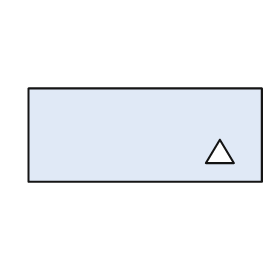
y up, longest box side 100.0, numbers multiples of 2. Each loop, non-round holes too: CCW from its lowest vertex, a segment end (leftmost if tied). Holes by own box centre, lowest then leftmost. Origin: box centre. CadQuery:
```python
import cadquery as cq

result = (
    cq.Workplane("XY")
    .moveTo(-50.0, -20.0)
    .lineTo(50.0, -20.0)
    .lineTo(50.0, 20.0)
    .lineTo(-50.0, 20.0)
    .close()
    .moveTo(26.0, -12.0)
    .lineTo(38.0, -12.0)
    .lineTo(32.0, -2.0)
    .close()
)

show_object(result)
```